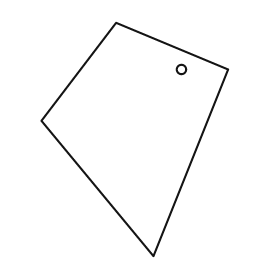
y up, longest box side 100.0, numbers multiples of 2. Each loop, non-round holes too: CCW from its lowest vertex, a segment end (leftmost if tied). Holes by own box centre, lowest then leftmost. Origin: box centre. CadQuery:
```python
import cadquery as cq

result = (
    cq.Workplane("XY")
    .moveTo(8.0, -50.0)
    .lineTo(40.0, 30.0)
    .lineTo(-8.0, 50.0)
    .lineTo(-40.0, 8.0)
    .close()
    .moveTo(20.0, 30.0)
    .circle(2.0)
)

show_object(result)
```